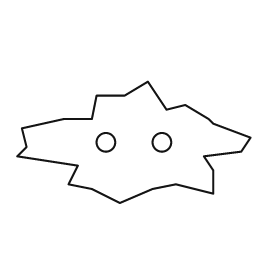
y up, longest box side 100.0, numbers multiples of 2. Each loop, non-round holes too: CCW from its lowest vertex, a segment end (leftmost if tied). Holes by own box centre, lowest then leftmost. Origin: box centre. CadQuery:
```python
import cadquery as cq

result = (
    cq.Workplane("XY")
    .moveTo(-6.0, -26.0)
    .lineTo(8.0, -20.0)
    .lineTo(18.0, -18.0)
    .lineTo(34.0, -22.0)
    .lineTo(34.0, -12.0)
    .lineTo(30.0, -6.0)
    .lineTo(46.0, -4.0)
    .lineTo(50.0, 2.0)
    .lineTo(34.0, 8.0)
    .lineTo(32.0, 10.0)
    .lineTo(22.0, 16.0)
    .lineTo(14.0, 14.0)
    .lineTo(6.0, 26.0)
    .lineTo(-4.0, 20.0)
    .lineTo(-16.0, 20.0)
    .lineTo(-18.0, 10.0)
    .lineTo(-30.0, 10.0)
    .lineTo(-48.0, 6.0)
    .lineTo(-46.0, -2.0)
    .lineTo(-50.0, -6.0)
    .lineTo(-24.0, -10.0)
    .lineTo(-28.0, -18.0)
    .lineTo(-18.0, -20.0)
    .close()
    .moveTo(-12.0, 0.0)
    .circle(4.0)
    .moveTo(12.0, 0.0)
    .circle(4.0)
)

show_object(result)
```